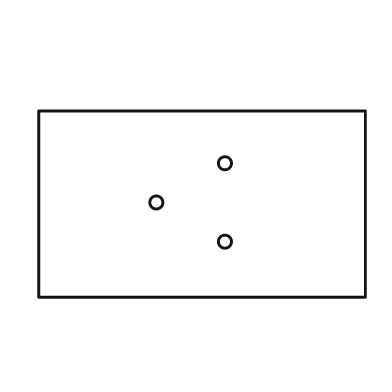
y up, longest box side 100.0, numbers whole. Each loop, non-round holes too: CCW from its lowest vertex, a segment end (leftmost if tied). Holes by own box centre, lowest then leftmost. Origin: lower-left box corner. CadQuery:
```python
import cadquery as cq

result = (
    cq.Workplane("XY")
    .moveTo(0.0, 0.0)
    .lineTo(100.0, 0.0)
    .lineTo(100.0, 57.0)
    .lineTo(0.0, 57.0)
    .close()
    .moveTo(57.0, 17.0)
    .circle(2.0)
    .moveTo(36.0, 29.0)
    .circle(2.0)
    .moveTo(57.0, 41.0)
    .circle(2.0)
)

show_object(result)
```